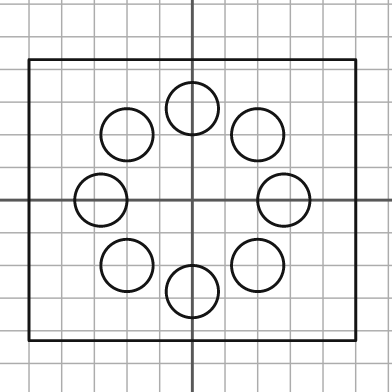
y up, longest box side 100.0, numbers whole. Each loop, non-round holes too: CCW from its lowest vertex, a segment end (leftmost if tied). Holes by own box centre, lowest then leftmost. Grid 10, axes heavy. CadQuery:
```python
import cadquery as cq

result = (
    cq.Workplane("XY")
    .moveTo(-50.0, -43.0)
    .lineTo(50.0, -43.0)
    .lineTo(50.0, 43.0)
    .lineTo(-50.0, 43.0)
    .close()
    .moveTo(0.0, -28.0)
    .circle(8.0)
    .moveTo(-20.0, -20.0)
    .circle(8.0)
    .moveTo(20.0, -20.0)
    .circle(8.0)
    .moveTo(-28.0, 0.0)
    .circle(8.0)
    .moveTo(28.0, 0.0)
    .circle(8.0)
    .moveTo(-20.0, 20.0)
    .circle(8.0)
    .moveTo(20.0, 20.0)
    .circle(8.0)
    .moveTo(0.0, 28.0)
    .circle(8.0)
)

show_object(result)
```